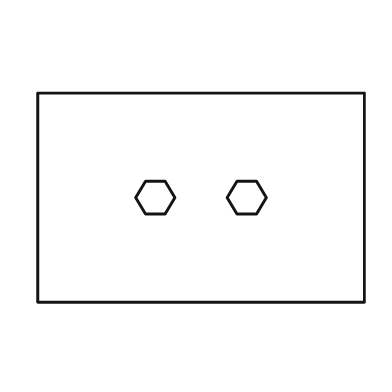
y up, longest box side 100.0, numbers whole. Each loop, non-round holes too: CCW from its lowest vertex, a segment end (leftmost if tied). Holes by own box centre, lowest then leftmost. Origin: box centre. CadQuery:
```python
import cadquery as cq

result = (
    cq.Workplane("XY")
    .moveTo(-50.0, -32.0)
    .lineTo(50.0, -32.0)
    .lineTo(50.0, 32.0)
    .lineTo(-50.0, 32.0)
    .close()
    .moveTo(-17.0, -5.0)
    .lineTo(-11.0, -5.0)
    .lineTo(-8.0, 0.0)
    .lineTo(-11.0, 5.0)
    .lineTo(-17.0, 5.0)
    .lineTo(-20.0, 0.0)
    .close()
    .moveTo(11.0, -5.0)
    .lineTo(17.0, -5.0)
    .lineTo(20.0, 0.0)
    .lineTo(17.0, 5.0)
    .lineTo(11.0, 5.0)
    .lineTo(8.0, 0.0)
    .close()
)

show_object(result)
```